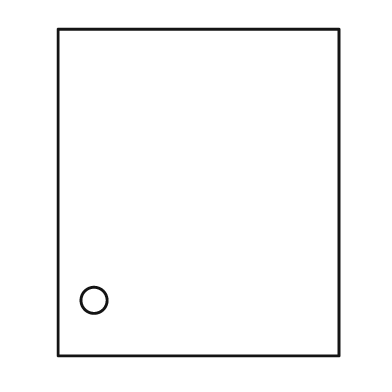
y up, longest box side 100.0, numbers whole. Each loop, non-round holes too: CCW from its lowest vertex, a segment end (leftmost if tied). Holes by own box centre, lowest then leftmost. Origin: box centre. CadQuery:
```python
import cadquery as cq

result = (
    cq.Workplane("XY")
    .moveTo(-43.0, -50.0)
    .lineTo(43.0, -50.0)
    .lineTo(43.0, 50.0)
    .lineTo(-43.0, 50.0)
    .close()
    .moveTo(-32.0, -33.0)
    .circle(4.0)
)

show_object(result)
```